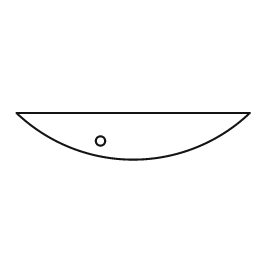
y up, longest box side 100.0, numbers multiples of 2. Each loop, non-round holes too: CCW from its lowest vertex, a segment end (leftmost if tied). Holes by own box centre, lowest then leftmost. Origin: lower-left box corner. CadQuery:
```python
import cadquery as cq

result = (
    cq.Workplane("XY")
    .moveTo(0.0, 20.0)
    .threePointArc((50.0, 0.0), (100.0, 20.0))
    .close()
    .moveTo(36.0, 8.0)
    .circle(2.0)
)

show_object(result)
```